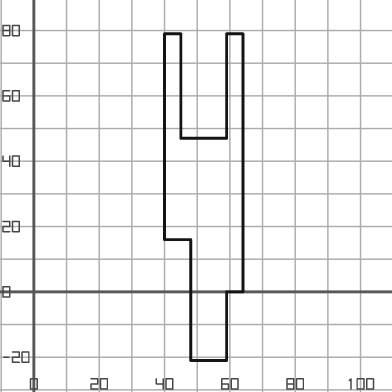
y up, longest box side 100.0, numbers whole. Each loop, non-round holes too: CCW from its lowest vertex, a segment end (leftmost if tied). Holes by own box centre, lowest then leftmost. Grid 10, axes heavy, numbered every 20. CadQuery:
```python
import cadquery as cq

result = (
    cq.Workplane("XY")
    .moveTo(48.0, -21.0)
    .lineTo(59.0, -21.0)
    .lineTo(59.0, 0.0)
    .lineTo(64.0, 0.0)
    .lineTo(64.0, 79.0)
    .lineTo(59.0, 79.0)
    .lineTo(59.0, 47.0)
    .lineTo(45.0, 47.0)
    .lineTo(45.0, 79.0)
    .lineTo(40.0, 79.0)
    .lineTo(40.0, 16.0)
    .lineTo(48.0, 16.0)
    .close()
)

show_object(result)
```